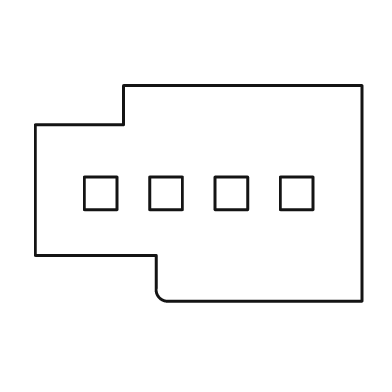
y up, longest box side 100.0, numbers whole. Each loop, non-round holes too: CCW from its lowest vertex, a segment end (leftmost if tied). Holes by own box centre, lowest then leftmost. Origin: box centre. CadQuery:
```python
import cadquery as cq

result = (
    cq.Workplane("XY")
    .moveTo(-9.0, -33.0)
    .lineTo(50.0, -33.0)
    .lineTo(50.0, 33.0)
    .lineTo(-23.0, 33.0)
    .lineTo(-23.0, 21.0)
    .lineTo(-50.0, 21.0)
    .lineTo(-50.0, -19.0)
    .lineTo(-13.0, -19.0)
    .lineTo(-13.0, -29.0)
    .threePointArc((-12.0, -32.0), (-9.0, -33.0))
    .close()
    .moveTo(-35.0, -5.0)
    .lineTo(-25.0, -5.0)
    .lineTo(-25.0, 5.0)
    .lineTo(-35.0, 5.0)
    .close()
    .moveTo(-15.0, -5.0)
    .lineTo(-5.0, -5.0)
    .lineTo(-5.0, 5.0)
    .lineTo(-15.0, 5.0)
    .close()
    .moveTo(5.0, -5.0)
    .lineTo(15.0, -5.0)
    .lineTo(15.0, 5.0)
    .lineTo(5.0, 5.0)
    .close()
    .moveTo(25.0, -5.0)
    .lineTo(35.0, -5.0)
    .lineTo(35.0, 5.0)
    .lineTo(25.0, 5.0)
    .close()
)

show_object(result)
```